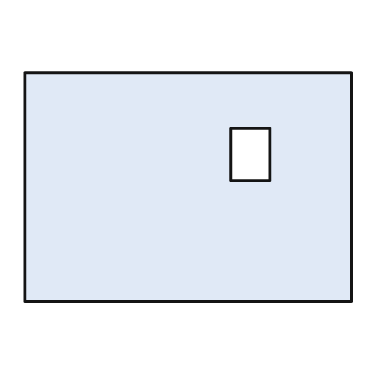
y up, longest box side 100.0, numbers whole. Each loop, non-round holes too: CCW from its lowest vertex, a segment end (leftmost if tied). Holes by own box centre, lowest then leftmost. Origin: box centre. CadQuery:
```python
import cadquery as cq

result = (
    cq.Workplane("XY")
    .moveTo(-50.0, -35.0)
    .lineTo(50.0, -35.0)
    .lineTo(50.0, 35.0)
    .lineTo(-50.0, 35.0)
    .close()
    .moveTo(13.0, 2.0)
    .lineTo(25.0, 2.0)
    .lineTo(25.0, 18.0)
    .lineTo(13.0, 18.0)
    .close()
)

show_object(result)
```